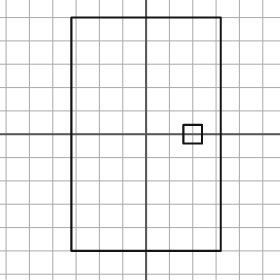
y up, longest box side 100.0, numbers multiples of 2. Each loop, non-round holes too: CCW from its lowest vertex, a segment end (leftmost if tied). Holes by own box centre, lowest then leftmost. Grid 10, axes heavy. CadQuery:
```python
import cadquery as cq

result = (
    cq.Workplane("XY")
    .moveTo(-32.0, -50.0)
    .lineTo(32.0, -50.0)
    .lineTo(32.0, 50.0)
    .lineTo(-32.0, 50.0)
    .close()
    .moveTo(16.0, -4.0)
    .lineTo(24.0, -4.0)
    .lineTo(24.0, 4.0)
    .lineTo(16.0, 4.0)
    .close()
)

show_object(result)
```